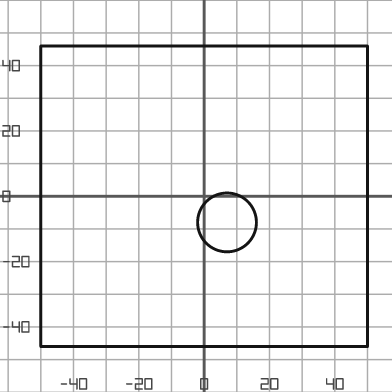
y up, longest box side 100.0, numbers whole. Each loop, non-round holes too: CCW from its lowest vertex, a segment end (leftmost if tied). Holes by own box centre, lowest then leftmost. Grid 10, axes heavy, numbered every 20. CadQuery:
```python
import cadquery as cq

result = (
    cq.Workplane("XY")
    .moveTo(-50.0, -46.0)
    .lineTo(50.0, -46.0)
    .lineTo(50.0, 46.0)
    .lineTo(-50.0, 46.0)
    .close()
    .moveTo(7.0, -8.0)
    .circle(9.0)
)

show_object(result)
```